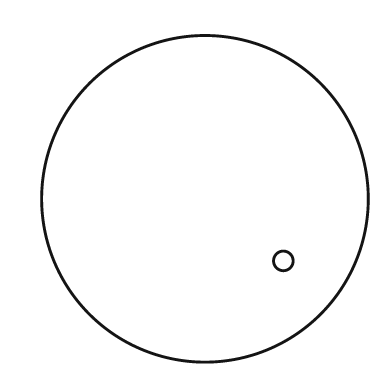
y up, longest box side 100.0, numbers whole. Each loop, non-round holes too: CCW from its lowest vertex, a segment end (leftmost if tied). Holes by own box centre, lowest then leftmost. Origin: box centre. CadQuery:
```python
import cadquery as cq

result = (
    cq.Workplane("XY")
    .moveTo(0.0, 0.0)
    .circle(50.0)
    .moveTo(24.0, -19.0)
    .circle(3.0)
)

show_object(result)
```